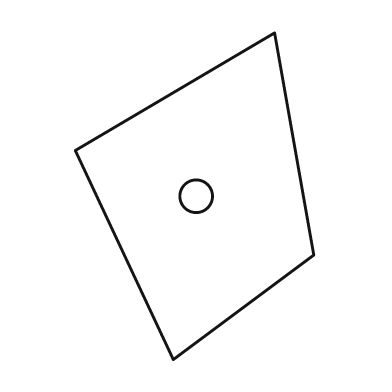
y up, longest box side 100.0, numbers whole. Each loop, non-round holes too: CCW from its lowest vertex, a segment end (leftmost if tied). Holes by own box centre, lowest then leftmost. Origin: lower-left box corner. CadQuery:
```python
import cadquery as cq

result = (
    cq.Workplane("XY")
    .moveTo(30.0, 0.0)
    .lineTo(73.0, 32.0)
    .lineTo(61.0, 100.0)
    .lineTo(0.0, 64.0)
    .close()
    .moveTo(37.0, 50.0)
    .circle(5.0)
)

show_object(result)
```